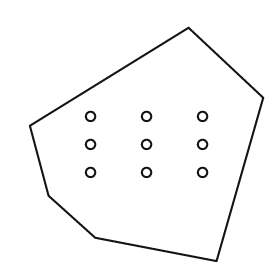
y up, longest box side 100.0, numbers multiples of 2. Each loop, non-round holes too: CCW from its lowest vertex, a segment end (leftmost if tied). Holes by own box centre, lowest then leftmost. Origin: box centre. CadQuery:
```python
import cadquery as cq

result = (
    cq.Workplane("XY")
    .moveTo(30.0, -50.0)
    .lineTo(50.0, 20.0)
    .lineTo(18.0, 50.0)
    .lineTo(-50.0, 8.0)
    .lineTo(-42.0, -22.0)
    .lineTo(-22.0, -40.0)
    .close()
    .moveTo(-24.0, -12.0)
    .circle(2.0)
    .moveTo(0.0, -12.0)
    .circle(2.0)
    .moveTo(24.0, -12.0)
    .circle(2.0)
    .moveTo(-24.0, 0.0)
    .circle(2.0)
    .moveTo(0.0, 0.0)
    .circle(2.0)
    .moveTo(24.0, 0.0)
    .circle(2.0)
    .moveTo(-24.0, 12.0)
    .circle(2.0)
    .moveTo(0.0, 12.0)
    .circle(2.0)
    .moveTo(24.0, 12.0)
    .circle(2.0)
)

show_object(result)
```